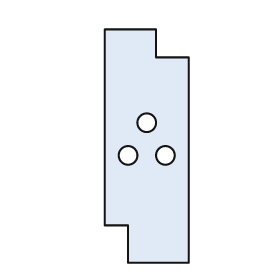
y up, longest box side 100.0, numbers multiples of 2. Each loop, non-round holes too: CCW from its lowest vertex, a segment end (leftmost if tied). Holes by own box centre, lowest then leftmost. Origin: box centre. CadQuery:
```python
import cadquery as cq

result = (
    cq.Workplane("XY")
    .moveTo(-8.0, -50.0)
    .lineTo(18.0, -50.0)
    .lineTo(18.0, 38.0)
    .lineTo(4.0, 38.0)
    .lineTo(4.0, 50.0)
    .lineTo(-18.0, 50.0)
    .lineTo(-18.0, -34.0)
    .lineTo(-8.0, -34.0)
    .close()
    .moveTo(-8.0, -4.0)
    .circle(4.0)
    .moveTo(8.0, -4.0)
    .circle(4.0)
    .moveTo(0.0, 10.0)
    .circle(4.0)
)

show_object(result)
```